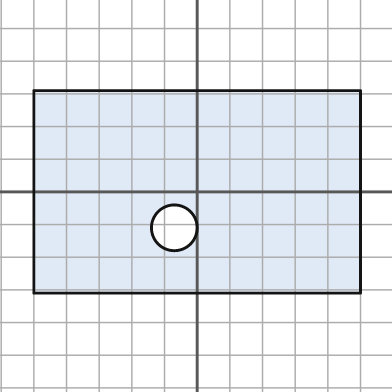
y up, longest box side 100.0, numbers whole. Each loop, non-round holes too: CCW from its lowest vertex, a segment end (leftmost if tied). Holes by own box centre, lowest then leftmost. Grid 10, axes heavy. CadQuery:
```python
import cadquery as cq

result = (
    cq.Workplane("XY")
    .moveTo(-50.0, -31.0)
    .lineTo(50.0, -31.0)
    .lineTo(50.0, 31.0)
    .lineTo(-50.0, 31.0)
    .close()
    .moveTo(-7.0, -11.0)
    .circle(7.0)
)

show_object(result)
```